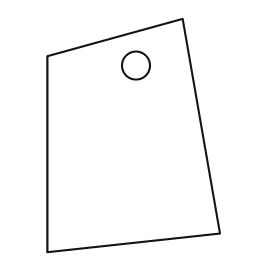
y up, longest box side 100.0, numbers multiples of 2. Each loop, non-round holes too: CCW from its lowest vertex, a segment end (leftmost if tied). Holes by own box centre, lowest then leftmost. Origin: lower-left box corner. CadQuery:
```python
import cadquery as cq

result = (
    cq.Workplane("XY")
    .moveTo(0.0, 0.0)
    .lineTo(74.0, 8.0)
    .lineTo(58.0, 100.0)
    .lineTo(0.0, 84.0)
    .close()
    .moveTo(38.0, 80.0)
    .circle(6.0)
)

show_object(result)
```